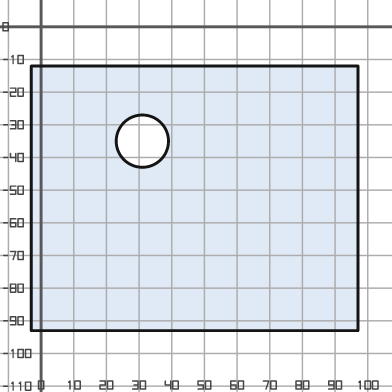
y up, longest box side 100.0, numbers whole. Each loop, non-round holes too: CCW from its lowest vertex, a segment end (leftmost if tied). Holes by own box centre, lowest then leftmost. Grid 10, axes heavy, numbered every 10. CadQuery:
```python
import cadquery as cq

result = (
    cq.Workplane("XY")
    .moveTo(-3.0, -93.0)
    .lineTo(97.0, -93.0)
    .lineTo(97.0, -12.0)
    .lineTo(-3.0, -12.0)
    .close()
    .moveTo(31.0, -35.0)
    .circle(8.0)
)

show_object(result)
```